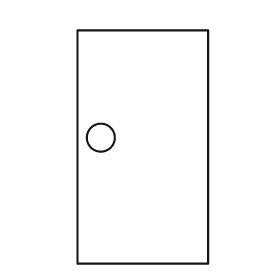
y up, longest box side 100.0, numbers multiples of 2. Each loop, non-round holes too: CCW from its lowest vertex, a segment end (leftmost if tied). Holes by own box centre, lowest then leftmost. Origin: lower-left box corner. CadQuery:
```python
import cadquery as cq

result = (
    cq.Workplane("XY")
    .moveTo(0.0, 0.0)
    .lineTo(56.0, 0.0)
    .lineTo(56.0, 100.0)
    .lineTo(0.0, 100.0)
    .close()
    .moveTo(10.0, 54.0)
    .circle(6.0)
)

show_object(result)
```